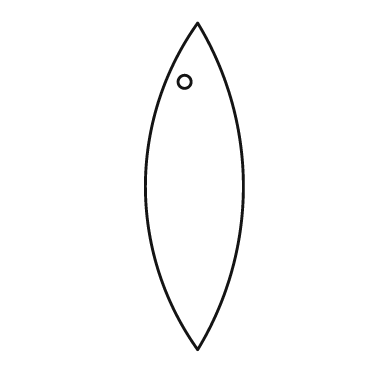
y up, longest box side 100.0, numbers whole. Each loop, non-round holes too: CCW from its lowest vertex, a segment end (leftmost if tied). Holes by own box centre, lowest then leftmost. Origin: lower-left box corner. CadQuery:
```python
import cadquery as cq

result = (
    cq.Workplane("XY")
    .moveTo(16.0, 0.0)
    .threePointArc((30.0, 50.0), (16.0, 100.0))
    .threePointArc((0.0, 50.0), (16.0, 0.0))
    .close()
    .moveTo(12.0, 82.0)
    .circle(2.0)
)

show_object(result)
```